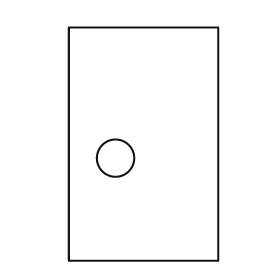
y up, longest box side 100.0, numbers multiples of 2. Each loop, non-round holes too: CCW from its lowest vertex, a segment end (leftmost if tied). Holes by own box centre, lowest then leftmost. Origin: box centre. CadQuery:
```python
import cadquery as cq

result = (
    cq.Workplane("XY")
    .moveTo(-32.0, -50.0)
    .lineTo(32.0, -50.0)
    .lineTo(32.0, 50.0)
    .lineTo(-32.0, 50.0)
    .close()
    .moveTo(-12.0, -6.0)
    .circle(8.0)
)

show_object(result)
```